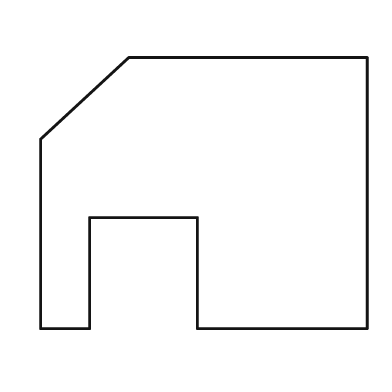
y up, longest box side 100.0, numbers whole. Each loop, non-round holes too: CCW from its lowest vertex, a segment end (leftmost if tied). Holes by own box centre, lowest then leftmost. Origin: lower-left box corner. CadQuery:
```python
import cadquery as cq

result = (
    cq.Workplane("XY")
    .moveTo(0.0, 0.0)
    .lineTo(15.0, 0.0)
    .lineTo(15.0, 34.0)
    .lineTo(48.0, 34.0)
    .lineTo(48.0, 0.0)
    .lineTo(100.0, 0.0)
    .lineTo(100.0, 83.0)
    .lineTo(27.0, 83.0)
    .lineTo(0.0, 58.0)
    .close()
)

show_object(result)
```